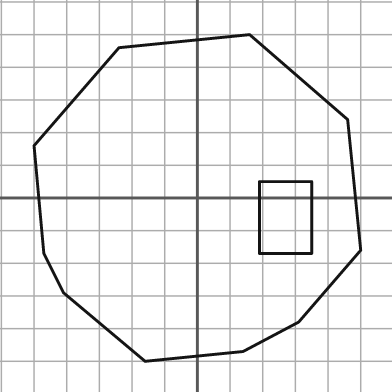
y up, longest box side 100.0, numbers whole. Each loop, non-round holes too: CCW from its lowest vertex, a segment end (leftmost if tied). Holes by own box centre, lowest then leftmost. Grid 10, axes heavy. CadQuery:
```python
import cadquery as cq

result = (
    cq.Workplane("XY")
    .moveTo(-16.0, -50.0)
    .lineTo(14.0, -47.0)
    .lineTo(31.0, -38.0)
    .lineTo(50.0, -16.0)
    .lineTo(46.0, 24.0)
    .lineTo(16.0, 50.0)
    .lineTo(-24.0, 46.0)
    .lineTo(-50.0, 16.0)
    .lineTo(-47.0, -17.0)
    .lineTo(-41.0, -29.0)
    .close()
    .moveTo(19.0, -17.0)
    .lineTo(35.0, -17.0)
    .lineTo(35.0, 5.0)
    .lineTo(19.0, 5.0)
    .close()
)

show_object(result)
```